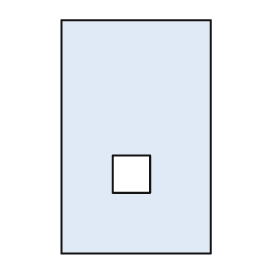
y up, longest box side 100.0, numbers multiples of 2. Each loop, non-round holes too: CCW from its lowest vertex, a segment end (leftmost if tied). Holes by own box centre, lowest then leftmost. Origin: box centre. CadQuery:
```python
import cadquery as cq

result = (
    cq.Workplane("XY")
    .moveTo(-32.0, -50.0)
    .lineTo(32.0, -50.0)
    .lineTo(32.0, 50.0)
    .lineTo(-32.0, 50.0)
    .close()
    .moveTo(-10.0, -24.0)
    .lineTo(6.0, -24.0)
    .lineTo(6.0, -8.0)
    .lineTo(-10.0, -8.0)
    .close()
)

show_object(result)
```